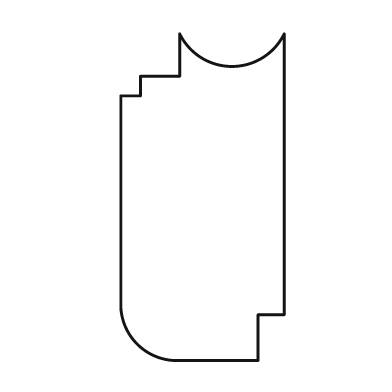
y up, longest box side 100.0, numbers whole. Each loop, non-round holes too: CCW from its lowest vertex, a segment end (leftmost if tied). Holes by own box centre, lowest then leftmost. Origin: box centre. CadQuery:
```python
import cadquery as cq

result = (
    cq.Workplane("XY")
    .moveTo(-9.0, -50.0)
    .lineTo(17.0, -50.0)
    .lineTo(17.0, -36.0)
    .lineTo(25.0, -36.0)
    .lineTo(25.0, 50.0)
    .threePointArc((9.0, 40.0), (-7.0, 50.0))
    .lineTo(-7.0, 37.0)
    .lineTo(-19.0, 37.0)
    .lineTo(-19.0, 31.0)
    .lineTo(-25.0, 31.0)
    .lineTo(-25.0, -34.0)
    .threePointArc((-20.0, -45.0), (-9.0, -50.0))
    .close()
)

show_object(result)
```